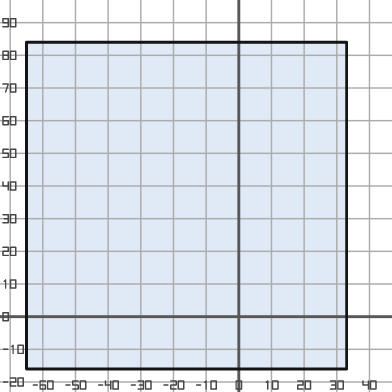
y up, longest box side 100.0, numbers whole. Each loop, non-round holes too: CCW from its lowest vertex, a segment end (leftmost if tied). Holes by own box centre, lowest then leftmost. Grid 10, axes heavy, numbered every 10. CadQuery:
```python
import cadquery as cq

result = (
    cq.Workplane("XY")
    .moveTo(-65.0, -16.0)
    .lineTo(33.0, -16.0)
    .lineTo(33.0, 84.0)
    .lineTo(-65.0, 84.0)
    .close()
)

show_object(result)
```